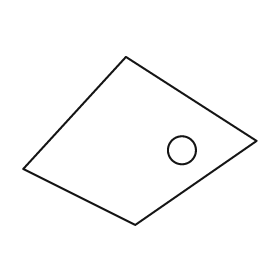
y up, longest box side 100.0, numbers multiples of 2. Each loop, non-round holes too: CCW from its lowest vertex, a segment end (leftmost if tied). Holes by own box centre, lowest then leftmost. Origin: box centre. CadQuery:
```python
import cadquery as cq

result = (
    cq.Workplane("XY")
    .moveTo(-2.0, -36.0)
    .lineTo(50.0, 0.0)
    .lineTo(-6.0, 36.0)
    .lineTo(-50.0, -12.0)
    .close()
    .moveTo(18.0, -4.0)
    .circle(6.0)
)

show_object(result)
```